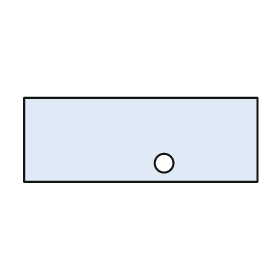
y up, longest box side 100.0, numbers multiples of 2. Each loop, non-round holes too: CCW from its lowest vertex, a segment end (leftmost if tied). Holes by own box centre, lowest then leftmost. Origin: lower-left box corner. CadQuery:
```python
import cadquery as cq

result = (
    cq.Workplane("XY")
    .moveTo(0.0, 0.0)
    .lineTo(100.0, 0.0)
    .lineTo(100.0, 36.0)
    .lineTo(0.0, 36.0)
    .close()
    .moveTo(60.0, 8.0)
    .circle(4.0)
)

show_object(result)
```